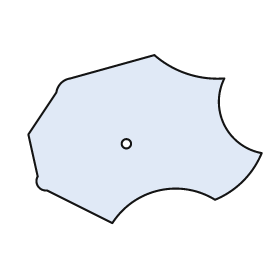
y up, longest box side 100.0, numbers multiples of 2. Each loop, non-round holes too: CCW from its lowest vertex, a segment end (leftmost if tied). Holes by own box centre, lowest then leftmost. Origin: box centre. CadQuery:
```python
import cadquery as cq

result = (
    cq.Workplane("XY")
    .moveTo(-14.0, -36.0)
    .threePointArc((6.0, -22.0), (30.0, -26.0))
    .threePointArc((42.0, -18.0), (50.0, -6.0))
    .threePointArc((34.0, 6.0), (34.0, 26.0))
    .threePointArc((18.0, 28.0), (4.0, 36.0))
    .lineTo(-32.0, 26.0)
    .threePointArc((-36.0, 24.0), (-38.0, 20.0))
    .lineTo(-50.0, 2.0)
    .lineTo(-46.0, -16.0)
    .threePointArc((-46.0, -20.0), (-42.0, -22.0))
    .close()
    .moveTo(-8.0, -2.0)
    .circle(2.0)
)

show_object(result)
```